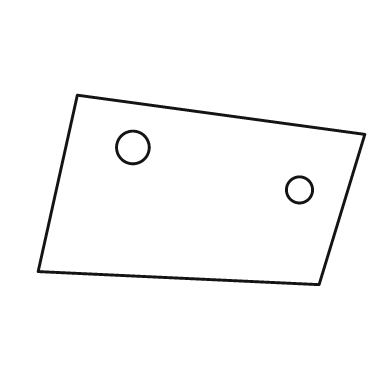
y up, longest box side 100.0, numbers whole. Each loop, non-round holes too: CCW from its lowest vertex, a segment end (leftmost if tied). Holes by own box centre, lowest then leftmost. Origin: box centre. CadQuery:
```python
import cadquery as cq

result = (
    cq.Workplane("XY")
    .moveTo(36.0, -29.0)
    .lineTo(50.0, 17.0)
    .lineTo(-38.0, 29.0)
    .lineTo(-50.0, -25.0)
    .close()
    .moveTo(30.0, 0.0)
    .circle(4.0)
    .moveTo(-21.0, 13.0)
    .circle(5.0)
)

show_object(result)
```